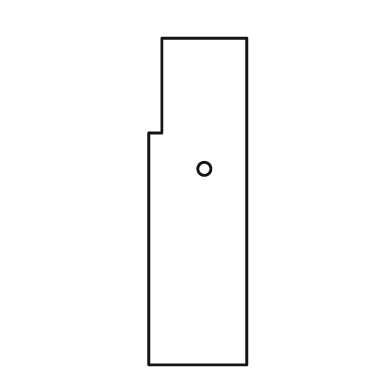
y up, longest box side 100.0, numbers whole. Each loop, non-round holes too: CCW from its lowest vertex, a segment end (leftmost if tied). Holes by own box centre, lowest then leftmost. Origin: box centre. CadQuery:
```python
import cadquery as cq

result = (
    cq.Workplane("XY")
    .moveTo(-15.0, -50.0)
    .lineTo(15.0, -50.0)
    .lineTo(15.0, 50.0)
    .lineTo(-11.0, 50.0)
    .lineTo(-11.0, 21.0)
    .lineTo(-15.0, 21.0)
    .close()
    .moveTo(2.0, 10.0)
    .circle(2.0)
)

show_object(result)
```